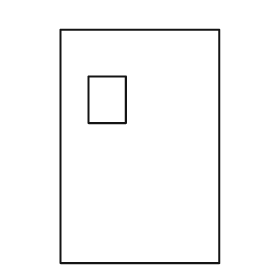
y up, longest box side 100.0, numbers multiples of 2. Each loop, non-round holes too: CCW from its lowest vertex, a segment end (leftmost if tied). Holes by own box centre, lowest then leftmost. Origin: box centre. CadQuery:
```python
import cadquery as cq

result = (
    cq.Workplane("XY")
    .moveTo(-34.0, -50.0)
    .lineTo(34.0, -50.0)
    .lineTo(34.0, 50.0)
    .lineTo(-34.0, 50.0)
    .close()
    .moveTo(-22.0, 10.0)
    .lineTo(-6.0, 10.0)
    .lineTo(-6.0, 30.0)
    .lineTo(-22.0, 30.0)
    .close()
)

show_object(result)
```